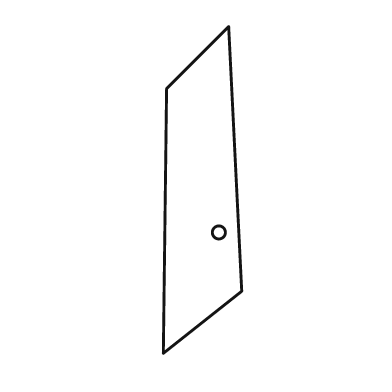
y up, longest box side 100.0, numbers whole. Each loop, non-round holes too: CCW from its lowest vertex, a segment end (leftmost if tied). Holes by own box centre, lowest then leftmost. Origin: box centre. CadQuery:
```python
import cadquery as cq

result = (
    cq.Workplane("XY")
    .moveTo(-12.0, -50.0)
    .lineTo(12.0, -31.0)
    .lineTo(8.0, 50.0)
    .lineTo(-11.0, 31.0)
    .close()
    .moveTo(5.0, -13.0)
    .circle(2.0)
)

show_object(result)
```